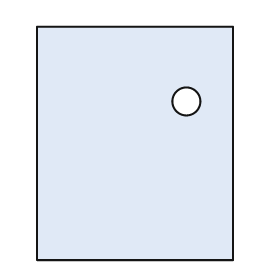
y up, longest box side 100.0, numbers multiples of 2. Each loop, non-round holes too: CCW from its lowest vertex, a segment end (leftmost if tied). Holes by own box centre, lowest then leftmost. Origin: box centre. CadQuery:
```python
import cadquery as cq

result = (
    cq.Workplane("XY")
    .moveTo(-42.0, -50.0)
    .lineTo(42.0, -50.0)
    .lineTo(42.0, 50.0)
    .lineTo(-42.0, 50.0)
    .close()
    .moveTo(22.0, 18.0)
    .circle(6.0)
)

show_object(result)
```